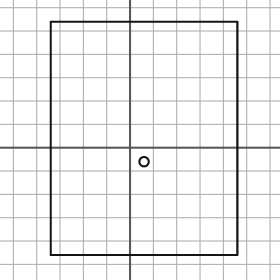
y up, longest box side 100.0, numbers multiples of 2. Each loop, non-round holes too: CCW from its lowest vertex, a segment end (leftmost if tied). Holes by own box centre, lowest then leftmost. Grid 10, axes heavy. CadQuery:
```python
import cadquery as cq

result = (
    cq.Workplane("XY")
    .moveTo(-34.0, -46.0)
    .lineTo(46.0, -46.0)
    .lineTo(46.0, 54.0)
    .lineTo(-34.0, 54.0)
    .close()
    .moveTo(6.0, -6.0)
    .circle(2.0)
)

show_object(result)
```